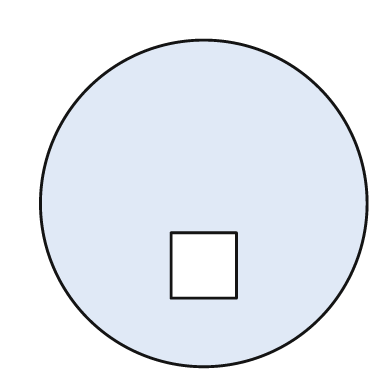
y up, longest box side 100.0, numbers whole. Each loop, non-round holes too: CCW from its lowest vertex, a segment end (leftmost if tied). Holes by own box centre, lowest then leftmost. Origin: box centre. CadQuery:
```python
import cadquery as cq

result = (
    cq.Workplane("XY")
    .moveTo(0.0, 0.0)
    .circle(50.0)
    .moveTo(-10.0, -29.0)
    .lineTo(10.0, -29.0)
    .lineTo(10.0, -9.0)
    .lineTo(-10.0, -9.0)
    .close()
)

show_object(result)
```